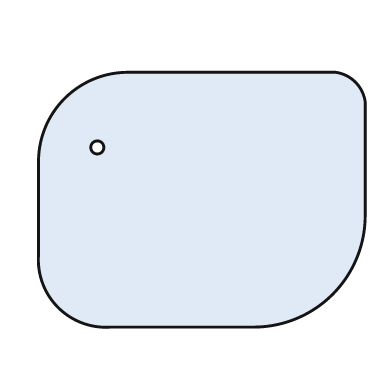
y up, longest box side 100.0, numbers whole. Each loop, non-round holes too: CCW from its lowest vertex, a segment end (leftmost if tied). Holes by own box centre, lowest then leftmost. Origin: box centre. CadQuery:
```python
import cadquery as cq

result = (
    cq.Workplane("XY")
    .moveTo(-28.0, -39.0)
    .lineTo(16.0, -39.0)
    .threePointArc((40.0, -29.0), (50.0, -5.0))
    .lineTo(50.0, 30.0)
    .threePointArc((47.0, 36.0), (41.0, 39.0))
    .lineTo(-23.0, 39.0)
    .threePointArc((-42.0, 31.0), (-50.0, 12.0))
    .lineTo(-50.0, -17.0)
    .threePointArc((-44.0, -33.0), (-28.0, -39.0))
    .close()
    .moveTo(-32.0, 16.0)
    .circle(2.0)
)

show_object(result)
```